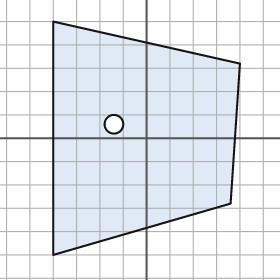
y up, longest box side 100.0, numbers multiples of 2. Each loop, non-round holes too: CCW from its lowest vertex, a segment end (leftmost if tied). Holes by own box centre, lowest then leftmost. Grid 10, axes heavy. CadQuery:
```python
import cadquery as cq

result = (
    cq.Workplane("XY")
    .moveTo(-40.0, -50.0)
    .lineTo(36.0, -28.0)
    .lineTo(40.0, 32.0)
    .lineTo(-40.0, 50.0)
    .close()
    .moveTo(-14.0, 6.0)
    .circle(4.0)
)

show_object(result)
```